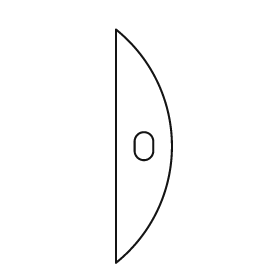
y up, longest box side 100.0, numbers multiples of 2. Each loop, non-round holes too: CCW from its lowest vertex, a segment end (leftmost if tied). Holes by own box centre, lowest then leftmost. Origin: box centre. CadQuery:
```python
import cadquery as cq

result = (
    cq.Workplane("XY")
    .moveTo(-12.0, -50.0)
    .threePointArc((12.0, 0.0), (-12.0, 50.0))
    .close()
    .moveTo(-4.0, -2.0)
    .threePointArc((0.0, -6.0), (4.0, -2.0))
    .lineTo(4.0, 2.0)
    .threePointArc((0.0, 6.0), (-4.0, 2.0))
    .close()
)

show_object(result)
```